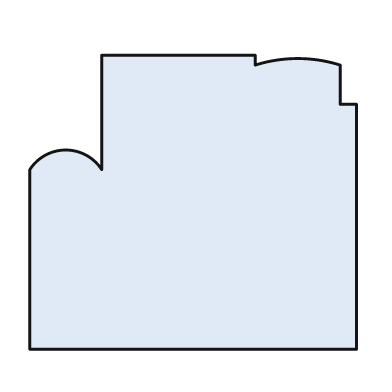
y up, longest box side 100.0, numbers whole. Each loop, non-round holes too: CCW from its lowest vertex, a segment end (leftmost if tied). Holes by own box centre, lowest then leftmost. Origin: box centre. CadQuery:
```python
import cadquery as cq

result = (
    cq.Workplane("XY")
    .moveTo(-50.0, -45.0)
    .lineTo(50.0, -45.0)
    .lineTo(50.0, 30.0)
    .lineTo(45.0, 30.0)
    .lineTo(45.0, 42.0)
    .threePointArc((32.0, 44.0), (19.0, 42.0))
    .lineTo(19.0, 45.0)
    .lineTo(-28.0, 45.0)
    .lineTo(-28.0, 10.0)
    .threePointArc((-39.0, 16.0), (-50.0, 10.0))
    .close()
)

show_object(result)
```